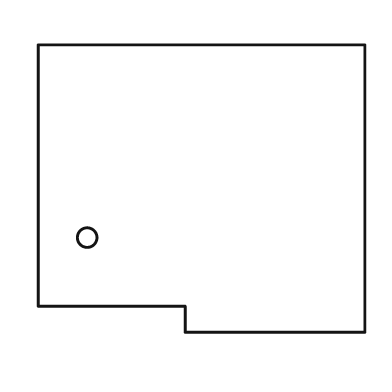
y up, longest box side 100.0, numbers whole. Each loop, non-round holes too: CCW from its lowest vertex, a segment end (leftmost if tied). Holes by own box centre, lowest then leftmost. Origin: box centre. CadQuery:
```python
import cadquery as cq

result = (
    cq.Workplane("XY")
    .moveTo(-5.0, -44.0)
    .lineTo(50.0, -44.0)
    .lineTo(50.0, 44.0)
    .lineTo(-50.0, 44.0)
    .lineTo(-50.0, -36.0)
    .lineTo(-5.0, -36.0)
    .close()
    .moveTo(-35.0, -15.0)
    .circle(3.0)
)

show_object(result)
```